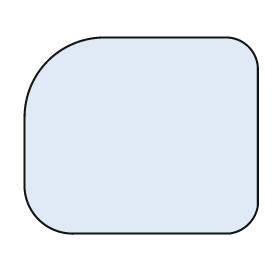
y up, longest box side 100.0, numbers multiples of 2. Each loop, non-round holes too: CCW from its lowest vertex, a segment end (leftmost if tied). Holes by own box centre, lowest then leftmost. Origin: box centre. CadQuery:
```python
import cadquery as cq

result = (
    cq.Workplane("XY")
    .moveTo(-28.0, -42.0)
    .lineTo(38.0, -42.0)
    .threePointArc((46.0, -38.0), (50.0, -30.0))
    .lineTo(50.0, 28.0)
    .threePointArc((46.0, 38.0), (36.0, 42.0))
    .lineTo(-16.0, 42.0)
    .threePointArc((-40.0, 32.0), (-50.0, 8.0))
    .lineTo(-50.0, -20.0)
    .threePointArc((-44.0, -36.0), (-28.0, -42.0))
    .close()
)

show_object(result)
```